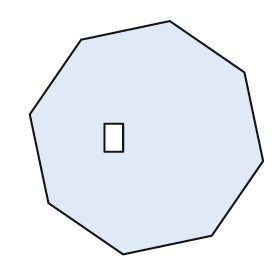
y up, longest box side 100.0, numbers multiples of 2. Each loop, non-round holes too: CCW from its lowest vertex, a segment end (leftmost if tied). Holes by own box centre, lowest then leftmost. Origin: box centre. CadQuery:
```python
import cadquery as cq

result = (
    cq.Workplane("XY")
    .moveTo(-10.0, -50.0)
    .lineTo(28.0, -42.0)
    .lineTo(50.0, -10.0)
    .lineTo(42.0, 28.0)
    .lineTo(10.0, 50.0)
    .lineTo(-28.0, 42.0)
    .lineTo(-50.0, 10.0)
    .lineTo(-42.0, -28.0)
    .close()
    .moveTo(-18.0, -6.0)
    .lineTo(-10.0, -6.0)
    .lineTo(-10.0, 6.0)
    .lineTo(-18.0, 6.0)
    .close()
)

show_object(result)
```